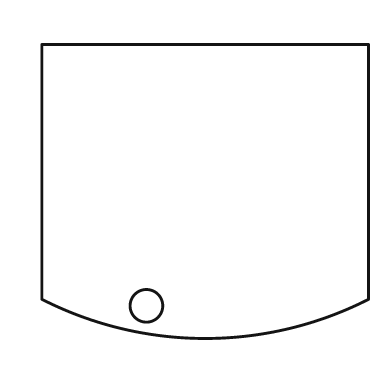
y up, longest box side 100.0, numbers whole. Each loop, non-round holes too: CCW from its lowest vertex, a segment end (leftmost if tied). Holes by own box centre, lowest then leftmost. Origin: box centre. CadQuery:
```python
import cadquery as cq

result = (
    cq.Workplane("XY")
    .moveTo(-50.0, -33.0)
    .threePointArc((0.0, -45.0), (50.0, -33.0))
    .lineTo(50.0, 45.0)
    .lineTo(-50.0, 45.0)
    .close()
    .moveTo(-18.0, -35.0)
    .circle(5.0)
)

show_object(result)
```